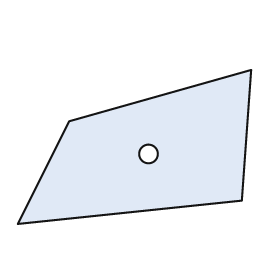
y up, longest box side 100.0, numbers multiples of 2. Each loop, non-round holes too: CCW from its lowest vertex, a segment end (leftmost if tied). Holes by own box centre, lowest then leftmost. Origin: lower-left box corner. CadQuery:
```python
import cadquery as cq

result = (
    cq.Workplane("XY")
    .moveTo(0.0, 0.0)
    .lineTo(96.0, 10.0)
    .lineTo(100.0, 66.0)
    .lineTo(22.0, 44.0)
    .close()
    .moveTo(56.0, 30.0)
    .circle(4.0)
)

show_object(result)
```